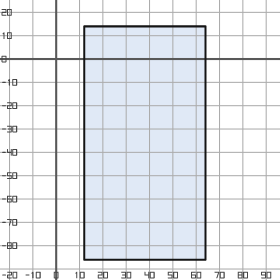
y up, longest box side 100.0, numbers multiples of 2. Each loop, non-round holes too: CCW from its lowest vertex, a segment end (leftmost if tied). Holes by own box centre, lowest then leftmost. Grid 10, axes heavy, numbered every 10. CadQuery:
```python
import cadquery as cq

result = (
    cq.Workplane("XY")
    .moveTo(12.0, -86.0)
    .lineTo(64.0, -86.0)
    .lineTo(64.0, 14.0)
    .lineTo(12.0, 14.0)
    .close()
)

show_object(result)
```